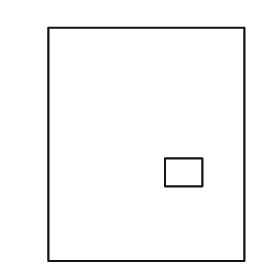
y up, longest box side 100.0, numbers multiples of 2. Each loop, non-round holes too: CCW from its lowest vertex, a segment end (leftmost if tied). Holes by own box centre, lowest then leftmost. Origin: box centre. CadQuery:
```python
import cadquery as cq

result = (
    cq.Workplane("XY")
    .moveTo(-42.0, -50.0)
    .lineTo(42.0, -50.0)
    .lineTo(42.0, 50.0)
    .lineTo(-42.0, 50.0)
    .close()
    .moveTo(8.0, -18.0)
    .lineTo(24.0, -18.0)
    .lineTo(24.0, -6.0)
    .lineTo(8.0, -6.0)
    .close()
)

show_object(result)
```